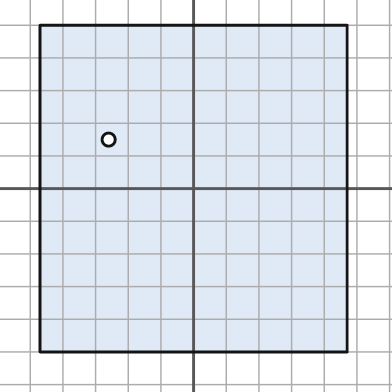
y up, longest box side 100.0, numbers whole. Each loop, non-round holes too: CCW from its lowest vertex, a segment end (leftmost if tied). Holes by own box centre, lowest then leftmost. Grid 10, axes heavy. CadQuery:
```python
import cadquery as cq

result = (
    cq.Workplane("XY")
    .moveTo(-47.0, -50.0)
    .lineTo(47.0, -50.0)
    .lineTo(47.0, 50.0)
    .lineTo(-47.0, 50.0)
    .close()
    .moveTo(-26.0, 15.0)
    .circle(2.0)
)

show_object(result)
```